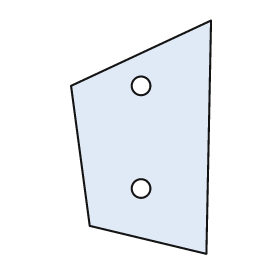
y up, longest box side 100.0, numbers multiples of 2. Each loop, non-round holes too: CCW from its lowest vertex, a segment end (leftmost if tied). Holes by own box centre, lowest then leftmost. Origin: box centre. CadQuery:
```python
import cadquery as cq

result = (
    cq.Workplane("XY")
    .moveTo(28.0, -50.0)
    .lineTo(30.0, 50.0)
    .lineTo(-30.0, 22.0)
    .lineTo(-22.0, -38.0)
    .close()
    .moveTo(0.0, -22.0)
    .circle(4.0)
    .moveTo(0.0, 22.0)
    .circle(4.0)
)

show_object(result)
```